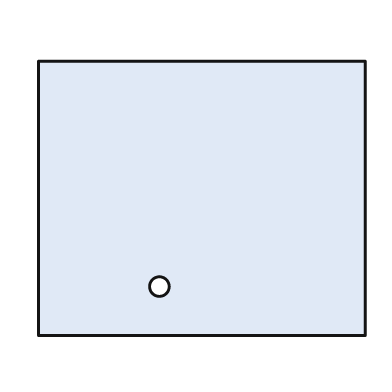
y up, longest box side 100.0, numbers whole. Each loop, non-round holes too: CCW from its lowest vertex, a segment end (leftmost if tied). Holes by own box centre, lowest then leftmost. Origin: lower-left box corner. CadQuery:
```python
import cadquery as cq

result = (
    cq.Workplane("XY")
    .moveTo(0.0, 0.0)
    .lineTo(100.0, 0.0)
    .lineTo(100.0, 84.0)
    .lineTo(0.0, 84.0)
    .close()
    .moveTo(37.0, 15.0)
    .circle(3.0)
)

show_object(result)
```